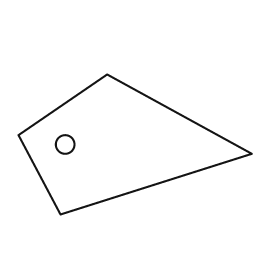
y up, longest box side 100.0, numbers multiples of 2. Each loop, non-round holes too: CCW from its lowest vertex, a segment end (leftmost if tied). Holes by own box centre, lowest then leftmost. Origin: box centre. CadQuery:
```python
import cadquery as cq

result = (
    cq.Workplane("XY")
    .moveTo(-32.0, -30.0)
    .lineTo(50.0, -4.0)
    .lineTo(-12.0, 30.0)
    .lineTo(-50.0, 4.0)
    .close()
    .moveTo(-30.0, 0.0)
    .circle(4.0)
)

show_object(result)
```